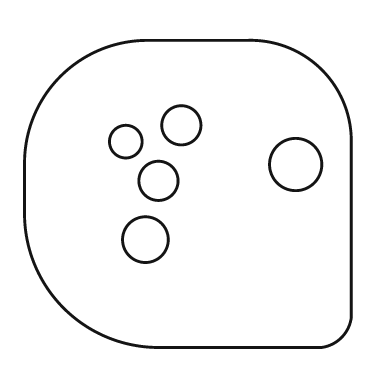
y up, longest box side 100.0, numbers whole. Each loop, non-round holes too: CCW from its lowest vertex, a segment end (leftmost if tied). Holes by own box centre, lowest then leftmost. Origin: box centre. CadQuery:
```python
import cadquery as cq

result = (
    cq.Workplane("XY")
    .moveTo(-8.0, -47.0)
    .lineTo(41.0, -47.0)
    .threePointArc((47.0, -44.0), (50.0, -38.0))
    .lineTo(50.0, 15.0)
    .threePointArc((41.0, 38.0), (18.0, 47.0))
    .lineTo(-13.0, 47.0)
    .threePointArc((-39.0, 36.0), (-50.0, 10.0))
    .lineTo(-50.0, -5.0)
    .threePointArc((-38.0, -35.0), (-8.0, -47.0))
    .close()
    .moveTo(-13.0, -14.0)
    .circle(7.0)
    .moveTo(-9.0, 4.0)
    .circle(6.0)
    .moveTo(33.0, 9.0)
    .circle(8.0)
    .moveTo(-19.0, 16.0)
    .circle(5.0)
    .moveTo(-2.0, 21.0)
    .circle(6.0)
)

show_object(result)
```